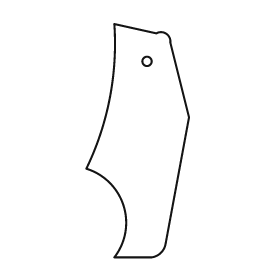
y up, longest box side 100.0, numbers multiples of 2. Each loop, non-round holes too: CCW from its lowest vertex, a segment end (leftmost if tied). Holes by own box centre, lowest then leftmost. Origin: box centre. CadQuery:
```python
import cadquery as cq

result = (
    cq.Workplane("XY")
    .moveTo(-10.0, -50.0)
    .lineTo(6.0, -50.0)
    .threePointArc((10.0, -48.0), (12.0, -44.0))
    .lineTo(22.0, 10.0)
    .lineTo(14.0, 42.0)
    .threePointArc((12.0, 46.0), (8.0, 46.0))
    .lineTo(-10.0, 50.0)
    .threePointArc((-12.0, 18.0), (-22.0, -12.0))
    .threePointArc((-6.0, -28.0), (-10.0, -50.0))
    .close()
    .moveTo(4.0, 34.0)
    .circle(2.0)
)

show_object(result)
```